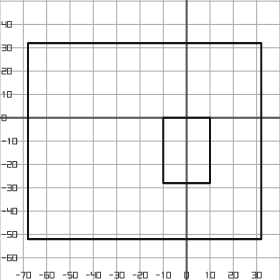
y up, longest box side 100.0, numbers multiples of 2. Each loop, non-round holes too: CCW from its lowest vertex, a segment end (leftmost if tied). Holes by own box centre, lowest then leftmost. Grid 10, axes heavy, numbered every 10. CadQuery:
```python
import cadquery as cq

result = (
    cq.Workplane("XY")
    .moveTo(-68.0, -52.0)
    .lineTo(32.0, -52.0)
    .lineTo(32.0, 32.0)
    .lineTo(-68.0, 32.0)
    .close()
    .moveTo(-10.0, -28.0)
    .lineTo(10.0, -28.0)
    .lineTo(10.0, 0.0)
    .lineTo(-10.0, 0.0)
    .close()
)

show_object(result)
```